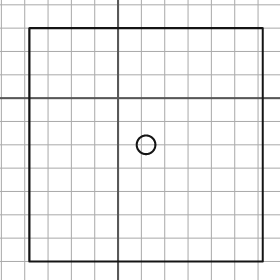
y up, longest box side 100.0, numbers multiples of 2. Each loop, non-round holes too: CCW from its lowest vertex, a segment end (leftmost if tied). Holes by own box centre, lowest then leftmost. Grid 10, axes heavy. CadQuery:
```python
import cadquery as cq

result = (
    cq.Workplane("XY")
    .moveTo(-38.0, -70.0)
    .lineTo(62.0, -70.0)
    .lineTo(62.0, 30.0)
    .lineTo(-38.0, 30.0)
    .close()
    .moveTo(12.0, -20.0)
    .circle(4.0)
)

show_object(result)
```